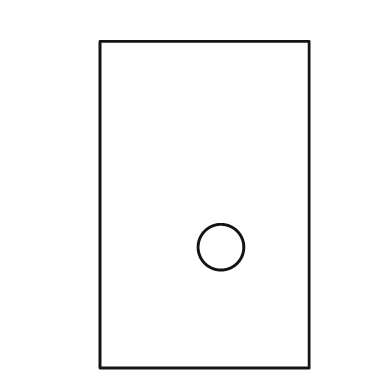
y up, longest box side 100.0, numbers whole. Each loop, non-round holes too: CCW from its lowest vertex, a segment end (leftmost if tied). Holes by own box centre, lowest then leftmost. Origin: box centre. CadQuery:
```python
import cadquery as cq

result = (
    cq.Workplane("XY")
    .moveTo(-32.0, -50.0)
    .lineTo(32.0, -50.0)
    .lineTo(32.0, 50.0)
    .lineTo(-32.0, 50.0)
    .close()
    .moveTo(5.0, -13.0)
    .circle(7.0)
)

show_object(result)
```